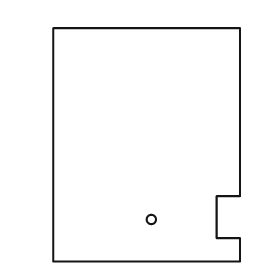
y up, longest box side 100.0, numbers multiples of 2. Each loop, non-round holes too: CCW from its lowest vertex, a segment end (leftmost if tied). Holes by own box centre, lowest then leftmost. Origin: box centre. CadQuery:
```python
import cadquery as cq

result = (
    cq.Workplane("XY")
    .moveTo(-40.0, -50.0)
    .lineTo(40.0, -50.0)
    .lineTo(40.0, -40.0)
    .lineTo(30.0, -40.0)
    .lineTo(30.0, -22.0)
    .lineTo(40.0, -22.0)
    .lineTo(40.0, 50.0)
    .lineTo(-40.0, 50.0)
    .close()
    .moveTo(2.0, -32.0)
    .circle(2.0)
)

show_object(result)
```